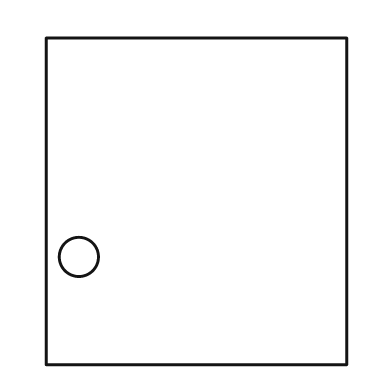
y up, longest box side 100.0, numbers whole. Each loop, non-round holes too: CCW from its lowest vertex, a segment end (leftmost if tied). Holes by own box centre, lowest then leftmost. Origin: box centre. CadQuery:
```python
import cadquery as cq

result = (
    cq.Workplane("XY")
    .moveTo(-46.0, -50.0)
    .lineTo(46.0, -50.0)
    .lineTo(46.0, 50.0)
    .lineTo(-46.0, 50.0)
    .close()
    .moveTo(-36.0, -17.0)
    .circle(6.0)
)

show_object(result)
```